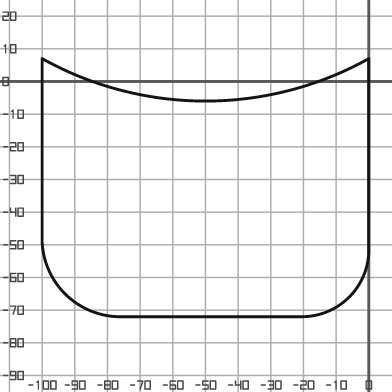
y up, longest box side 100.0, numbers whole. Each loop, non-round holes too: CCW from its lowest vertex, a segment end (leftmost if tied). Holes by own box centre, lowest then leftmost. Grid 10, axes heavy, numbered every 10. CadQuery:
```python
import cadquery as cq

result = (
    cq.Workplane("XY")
    .moveTo(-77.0, -72.0)
    .lineTo(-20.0, -72.0)
    .threePointArc((-6.0, -66.0), (0.0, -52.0))
    .lineTo(0.0, 7.0)
    .threePointArc((-50.0, -6.0), (-100.0, 7.0))
    .lineTo(-100.0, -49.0)
    .threePointArc((-93.0, -65.0), (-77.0, -72.0))
    .close()
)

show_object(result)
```